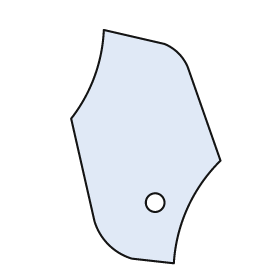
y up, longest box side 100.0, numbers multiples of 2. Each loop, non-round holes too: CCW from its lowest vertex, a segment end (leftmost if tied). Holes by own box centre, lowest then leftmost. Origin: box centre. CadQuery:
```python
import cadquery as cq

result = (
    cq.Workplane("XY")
    .moveTo(12.0, -50.0)
    .threePointArc((18.0, -26.0), (32.0, -6.0))
    .lineTo(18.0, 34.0)
    .threePointArc((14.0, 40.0), (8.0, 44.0))
    .lineTo(-18.0, 50.0)
    .threePointArc((-22.0, 30.0), (-32.0, 12.0))
    .lineTo(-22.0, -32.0)
    .threePointArc((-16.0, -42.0), (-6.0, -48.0))
    .close()
    .moveTo(4.0, -24.0)
    .circle(4.0)
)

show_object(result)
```